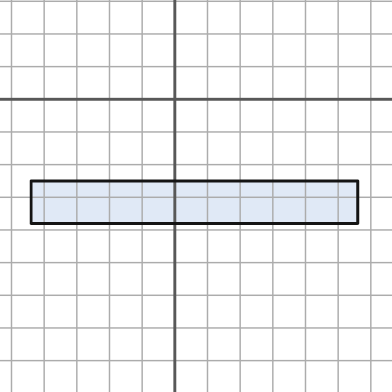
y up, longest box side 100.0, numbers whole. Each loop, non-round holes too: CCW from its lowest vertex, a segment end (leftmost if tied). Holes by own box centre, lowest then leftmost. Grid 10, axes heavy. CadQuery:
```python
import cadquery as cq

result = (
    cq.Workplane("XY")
    .moveTo(-44.0, -38.0)
    .lineTo(56.0, -38.0)
    .lineTo(56.0, -25.0)
    .lineTo(-44.0, -25.0)
    .close()
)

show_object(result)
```